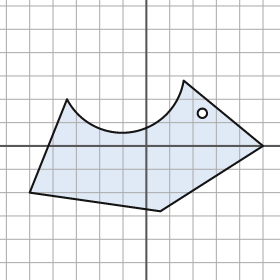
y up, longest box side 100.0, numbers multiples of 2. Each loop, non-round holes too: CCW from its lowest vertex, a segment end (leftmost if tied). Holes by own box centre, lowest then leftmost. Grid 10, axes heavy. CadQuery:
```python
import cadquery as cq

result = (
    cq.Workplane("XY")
    .moveTo(6.0, -28.0)
    .lineTo(50.0, 0.0)
    .lineTo(16.0, 28.0)
    .threePointArc((-6.0, 6.0), (-34.0, 20.0))
    .lineTo(-50.0, -20.0)
    .close()
    .moveTo(24.0, 14.0)
    .circle(2.0)
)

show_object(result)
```